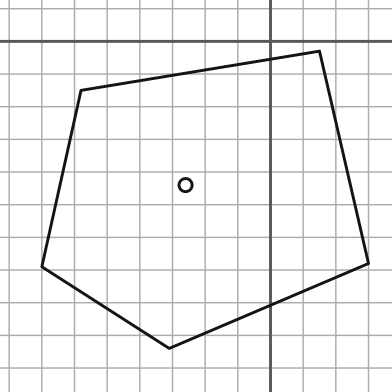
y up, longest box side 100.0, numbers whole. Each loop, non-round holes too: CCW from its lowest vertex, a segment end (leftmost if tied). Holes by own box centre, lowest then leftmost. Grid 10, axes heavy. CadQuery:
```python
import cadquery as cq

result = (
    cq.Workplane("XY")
    .moveTo(-31.0, -94.0)
    .lineTo(30.0, -68.0)
    .lineTo(15.0, -3.0)
    .lineTo(-58.0, -15.0)
    .lineTo(-70.0, -69.0)
    .close()
    .moveTo(-26.0, -44.0)
    .circle(2.0)
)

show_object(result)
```